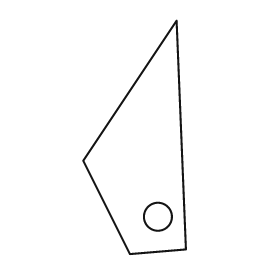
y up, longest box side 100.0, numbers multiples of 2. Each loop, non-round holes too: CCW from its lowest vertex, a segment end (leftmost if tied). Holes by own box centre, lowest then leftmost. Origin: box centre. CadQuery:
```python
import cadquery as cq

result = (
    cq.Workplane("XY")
    .moveTo(-2.0, -50.0)
    .lineTo(22.0, -48.0)
    .lineTo(18.0, 50.0)
    .lineTo(-22.0, -10.0)
    .close()
    .moveTo(10.0, -34.0)
    .circle(6.0)
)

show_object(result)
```